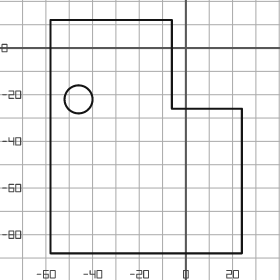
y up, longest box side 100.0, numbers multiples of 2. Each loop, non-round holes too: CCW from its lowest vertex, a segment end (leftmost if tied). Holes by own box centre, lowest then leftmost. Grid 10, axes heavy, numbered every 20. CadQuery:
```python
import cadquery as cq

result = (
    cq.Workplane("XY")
    .moveTo(-58.0, -88.0)
    .lineTo(24.0, -88.0)
    .lineTo(24.0, -26.0)
    .lineTo(-6.0, -26.0)
    .lineTo(-6.0, 12.0)
    .lineTo(-58.0, 12.0)
    .close()
    .moveTo(-46.0, -22.0)
    .circle(6.0)
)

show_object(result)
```